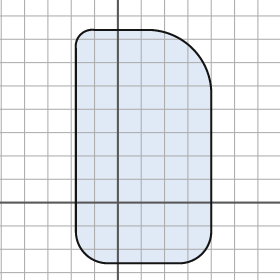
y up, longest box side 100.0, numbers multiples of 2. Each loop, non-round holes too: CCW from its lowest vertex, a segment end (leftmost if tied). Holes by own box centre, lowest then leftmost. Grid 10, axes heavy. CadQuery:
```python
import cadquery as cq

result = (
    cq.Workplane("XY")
    .moveTo(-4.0, -26.0)
    .lineTo(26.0, -26.0)
    .threePointArc((36.0, -22.0), (40.0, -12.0))
    .lineTo(40.0, 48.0)
    .threePointArc((32.0, 66.0), (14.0, 74.0))
    .lineTo(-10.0, 74.0)
    .threePointArc((-16.0, 72.0), (-18.0, 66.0))
    .lineTo(-18.0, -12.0)
    .threePointArc((-14.0, -22.0), (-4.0, -26.0))
    .close()
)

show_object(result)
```